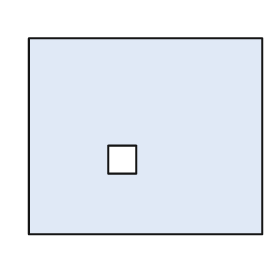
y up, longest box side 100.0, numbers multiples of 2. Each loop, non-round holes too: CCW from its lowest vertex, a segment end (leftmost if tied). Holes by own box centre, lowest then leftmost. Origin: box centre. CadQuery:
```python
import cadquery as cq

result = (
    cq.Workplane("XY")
    .moveTo(-50.0, -42.0)
    .lineTo(50.0, -42.0)
    .lineTo(50.0, 42.0)
    .lineTo(-50.0, 42.0)
    .close()
    .moveTo(-16.0, -16.0)
    .lineTo(-4.0, -16.0)
    .lineTo(-4.0, -4.0)
    .lineTo(-16.0, -4.0)
    .close()
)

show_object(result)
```